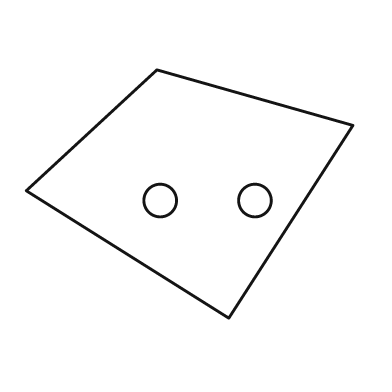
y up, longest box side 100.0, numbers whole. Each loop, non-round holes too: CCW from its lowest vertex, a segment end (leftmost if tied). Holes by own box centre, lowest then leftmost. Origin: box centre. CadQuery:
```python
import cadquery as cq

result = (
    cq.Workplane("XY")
    .moveTo(12.0, -38.0)
    .lineTo(50.0, 21.0)
    .lineTo(-10.0, 38.0)
    .lineTo(-50.0, 1.0)
    .close()
    .moveTo(-9.0, -2.0)
    .circle(5.0)
    .moveTo(20.0, -2.0)
    .circle(5.0)
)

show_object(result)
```